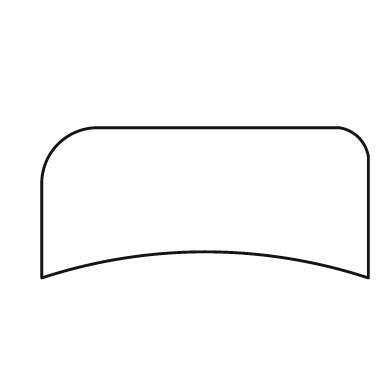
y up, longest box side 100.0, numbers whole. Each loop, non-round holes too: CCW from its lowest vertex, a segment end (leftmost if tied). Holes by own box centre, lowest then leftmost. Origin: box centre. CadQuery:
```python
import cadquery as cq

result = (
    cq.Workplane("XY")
    .moveTo(-50.0, -23.0)
    .threePointArc((0.0, -15.0), (50.0, -23.0))
    .lineTo(50.0, 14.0)
    .threePointArc((47.0, 20.0), (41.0, 23.0))
    .lineTo(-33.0, 23.0)
    .threePointArc((-45.0, 18.0), (-50.0, 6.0))
    .close()
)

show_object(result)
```